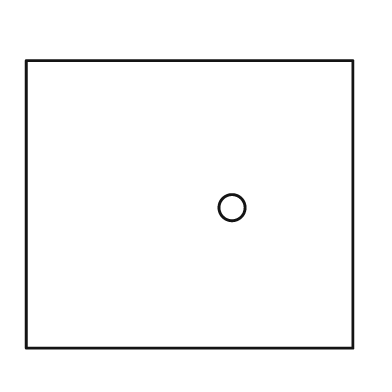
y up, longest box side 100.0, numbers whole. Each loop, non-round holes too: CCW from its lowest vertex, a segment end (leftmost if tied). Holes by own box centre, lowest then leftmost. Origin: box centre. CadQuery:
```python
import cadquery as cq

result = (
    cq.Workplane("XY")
    .moveTo(-50.0, -44.0)
    .lineTo(50.0, -44.0)
    .lineTo(50.0, 44.0)
    .lineTo(-50.0, 44.0)
    .close()
    .moveTo(13.0, -1.0)
    .circle(4.0)
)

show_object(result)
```